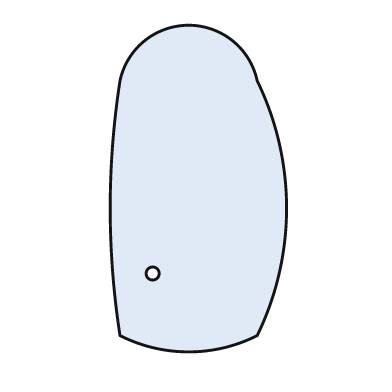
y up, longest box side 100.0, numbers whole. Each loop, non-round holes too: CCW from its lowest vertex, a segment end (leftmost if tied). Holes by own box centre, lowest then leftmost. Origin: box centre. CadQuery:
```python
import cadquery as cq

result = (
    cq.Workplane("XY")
    .moveTo(-24.0, -45.0)
    .threePointArc((-3.0, -50.0), (18.0, -45.0))
    .threePointArc((27.0, -6.0), (18.0, 33.0))
    .threePointArc((-3.0, 50.0), (-24.0, 33.0))
    .threePointArc((-27.0, -6.0), (-24.0, -45.0))
    .close()
    .moveTo(-14.0, -26.0)
    .circle(2.0)
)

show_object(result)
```